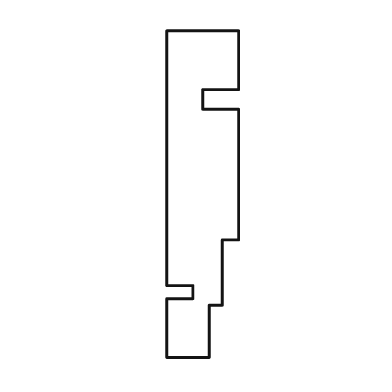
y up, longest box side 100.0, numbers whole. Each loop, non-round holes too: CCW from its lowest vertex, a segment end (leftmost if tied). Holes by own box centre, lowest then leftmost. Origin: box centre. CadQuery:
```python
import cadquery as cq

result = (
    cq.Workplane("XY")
    .moveTo(-11.0, -50.0)
    .lineTo(2.0, -50.0)
    .lineTo(2.0, -34.0)
    .lineTo(6.0, -34.0)
    .lineTo(6.0, -14.0)
    .lineTo(11.0, -14.0)
    .lineTo(11.0, 26.0)
    .lineTo(0.0, 26.0)
    .lineTo(0.0, 32.0)
    .lineTo(11.0, 32.0)
    .lineTo(11.0, 50.0)
    .lineTo(-11.0, 50.0)
    .lineTo(-11.0, -28.0)
    .lineTo(-3.0, -28.0)
    .lineTo(-3.0, -32.0)
    .lineTo(-11.0, -32.0)
    .close()
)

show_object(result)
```